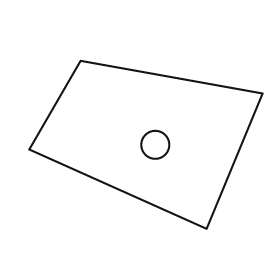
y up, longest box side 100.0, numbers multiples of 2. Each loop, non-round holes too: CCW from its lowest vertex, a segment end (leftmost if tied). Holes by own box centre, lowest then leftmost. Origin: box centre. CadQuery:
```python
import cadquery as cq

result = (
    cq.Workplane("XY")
    .moveTo(26.0, -36.0)
    .lineTo(50.0, 22.0)
    .lineTo(-28.0, 36.0)
    .lineTo(-50.0, -2.0)
    .close()
    .moveTo(4.0, 0.0)
    .circle(6.0)
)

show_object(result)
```